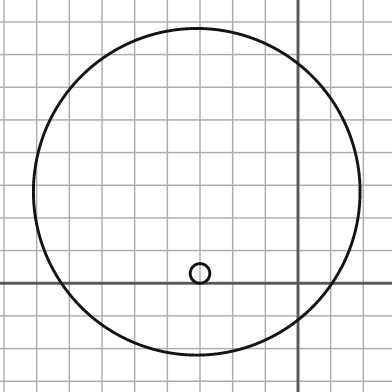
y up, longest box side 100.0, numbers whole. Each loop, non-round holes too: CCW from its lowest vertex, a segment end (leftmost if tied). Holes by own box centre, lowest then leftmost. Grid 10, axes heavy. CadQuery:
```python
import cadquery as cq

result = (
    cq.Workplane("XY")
    .moveTo(-31.0, 28.0)
    .circle(50.0)
    .moveTo(-30.0, 3.0)
    .circle(3.0)
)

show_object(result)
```